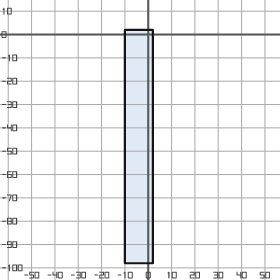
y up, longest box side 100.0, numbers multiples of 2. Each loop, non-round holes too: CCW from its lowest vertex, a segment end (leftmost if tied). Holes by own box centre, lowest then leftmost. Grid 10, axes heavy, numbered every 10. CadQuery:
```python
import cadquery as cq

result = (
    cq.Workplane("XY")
    .moveTo(-10.0, -98.0)
    .lineTo(2.0, -98.0)
    .lineTo(2.0, 2.0)
    .lineTo(-10.0, 2.0)
    .close()
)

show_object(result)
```